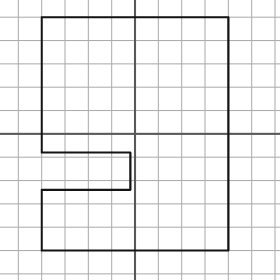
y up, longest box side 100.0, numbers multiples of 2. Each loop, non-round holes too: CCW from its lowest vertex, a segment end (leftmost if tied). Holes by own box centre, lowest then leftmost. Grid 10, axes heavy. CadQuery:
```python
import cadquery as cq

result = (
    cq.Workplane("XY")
    .moveTo(-40.0, -50.0)
    .lineTo(40.0, -50.0)
    .lineTo(40.0, 50.0)
    .lineTo(-40.0, 50.0)
    .lineTo(-40.0, -8.0)
    .lineTo(-2.0, -8.0)
    .lineTo(-2.0, -24.0)
    .lineTo(-40.0, -24.0)
    .close()
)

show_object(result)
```